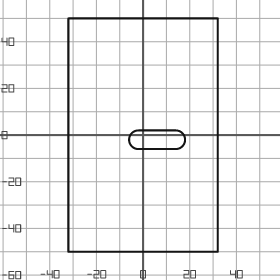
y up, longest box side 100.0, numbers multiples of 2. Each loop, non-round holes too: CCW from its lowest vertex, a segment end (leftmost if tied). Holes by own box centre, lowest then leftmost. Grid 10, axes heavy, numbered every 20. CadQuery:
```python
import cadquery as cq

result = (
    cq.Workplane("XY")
    .moveTo(-32.0, -50.0)
    .lineTo(32.0, -50.0)
    .lineTo(32.0, 50.0)
    .lineTo(-32.0, 50.0)
    .close()
    .moveTo(-2.0, -6.0)
    .lineTo(14.0, -6.0)
    .threePointArc((18.0, -2.0), (14.0, 2.0))
    .lineTo(-2.0, 2.0)
    .threePointArc((-6.0, -2.0), (-2.0, -6.0))
    .close()
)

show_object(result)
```